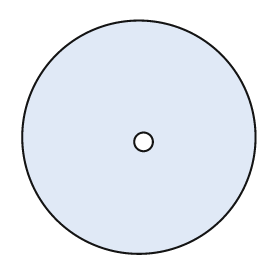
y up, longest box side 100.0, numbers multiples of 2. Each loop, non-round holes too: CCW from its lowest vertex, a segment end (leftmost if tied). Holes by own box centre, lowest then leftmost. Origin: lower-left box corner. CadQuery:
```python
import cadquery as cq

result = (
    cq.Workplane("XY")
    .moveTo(50.0, 50.0)
    .circle(50.0)
    .moveTo(52.0, 48.0)
    .circle(4.0)
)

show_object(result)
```